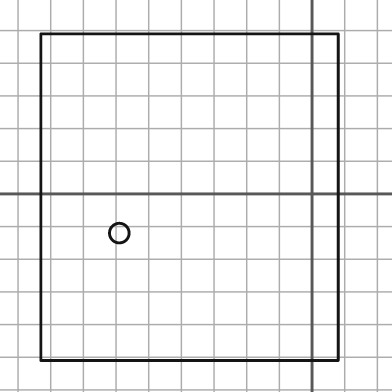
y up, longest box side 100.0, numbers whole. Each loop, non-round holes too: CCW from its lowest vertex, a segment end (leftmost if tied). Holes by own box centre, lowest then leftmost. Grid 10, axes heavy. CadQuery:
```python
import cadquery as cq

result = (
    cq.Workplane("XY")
    .moveTo(-83.0, -51.0)
    .lineTo(8.0, -51.0)
    .lineTo(8.0, 49.0)
    .lineTo(-83.0, 49.0)
    .close()
    .moveTo(-59.0, -12.0)
    .circle(3.0)
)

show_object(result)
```